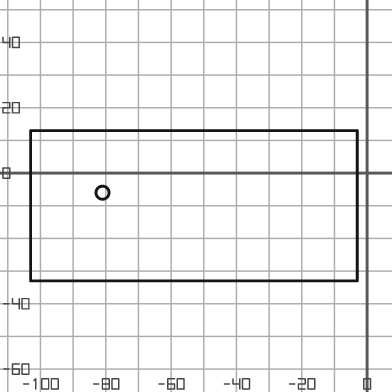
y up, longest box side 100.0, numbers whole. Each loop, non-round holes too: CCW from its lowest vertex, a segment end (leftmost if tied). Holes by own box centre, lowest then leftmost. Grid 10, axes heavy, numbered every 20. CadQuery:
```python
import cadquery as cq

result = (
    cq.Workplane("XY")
    .moveTo(-103.0, -33.0)
    .lineTo(-3.0, -33.0)
    .lineTo(-3.0, 13.0)
    .lineTo(-103.0, 13.0)
    .close()
    .moveTo(-81.0, -6.0)
    .circle(2.0)
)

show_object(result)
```